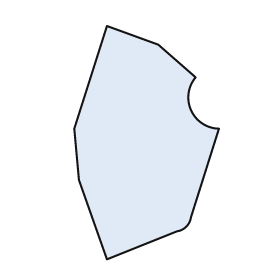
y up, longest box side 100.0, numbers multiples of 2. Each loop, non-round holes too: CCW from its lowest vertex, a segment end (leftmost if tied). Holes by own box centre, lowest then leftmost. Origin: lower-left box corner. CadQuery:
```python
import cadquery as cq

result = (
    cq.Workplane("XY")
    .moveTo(14.0, 0.0)
    .lineTo(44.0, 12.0)
    .threePointArc((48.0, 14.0), (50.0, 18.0))
    .lineTo(62.0, 56.0)
    .threePointArc((50.0, 64.0), (52.0, 78.0))
    .lineTo(36.0, 92.0)
    .lineTo(14.0, 100.0)
    .lineTo(0.0, 56.0)
    .lineTo(2.0, 34.0)
    .close()
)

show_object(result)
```